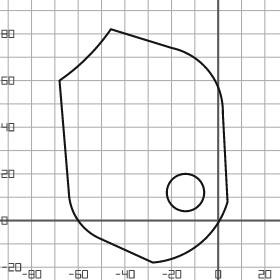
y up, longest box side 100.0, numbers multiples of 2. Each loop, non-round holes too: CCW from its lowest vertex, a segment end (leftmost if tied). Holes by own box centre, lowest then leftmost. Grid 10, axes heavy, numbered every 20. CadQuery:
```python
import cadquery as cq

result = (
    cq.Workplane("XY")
    .moveTo(-28.0, -18.0)
    .threePointArc((-8.0, -10.0), (4.0, 8.0))
    .lineTo(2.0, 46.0)
    .threePointArc((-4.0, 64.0), (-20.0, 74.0))
    .lineTo(-46.0, 82.0)
    .threePointArc((-56.0, 70.0), (-68.0, 60.0))
    .lineTo(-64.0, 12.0)
    .threePointArc((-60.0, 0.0), (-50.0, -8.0))
    .close()
    .moveTo(-14.0, 12.0)
    .circle(8.0)
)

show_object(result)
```